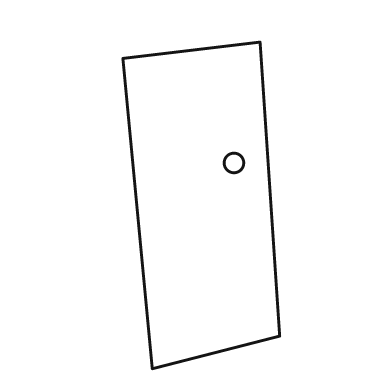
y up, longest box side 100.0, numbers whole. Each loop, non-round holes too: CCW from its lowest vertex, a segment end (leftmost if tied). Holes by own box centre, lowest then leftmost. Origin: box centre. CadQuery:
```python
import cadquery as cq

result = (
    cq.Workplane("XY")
    .moveTo(-15.0, -50.0)
    .lineTo(24.0, -40.0)
    .lineTo(18.0, 50.0)
    .lineTo(-24.0, 45.0)
    .close()
    .moveTo(10.0, 13.0)
    .circle(3.0)
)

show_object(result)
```